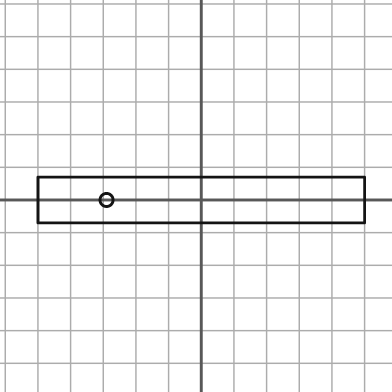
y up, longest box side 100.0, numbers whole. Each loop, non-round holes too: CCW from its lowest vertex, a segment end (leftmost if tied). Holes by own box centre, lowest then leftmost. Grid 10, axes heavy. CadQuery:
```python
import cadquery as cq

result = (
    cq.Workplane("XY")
    .moveTo(-50.0, -7.0)
    .lineTo(50.0, -7.0)
    .lineTo(50.0, 7.0)
    .lineTo(-50.0, 7.0)
    .close()
    .moveTo(-29.0, 0.0)
    .circle(2.0)
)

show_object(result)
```